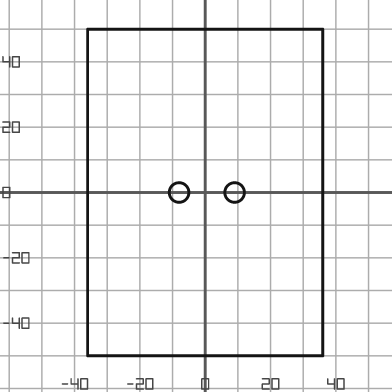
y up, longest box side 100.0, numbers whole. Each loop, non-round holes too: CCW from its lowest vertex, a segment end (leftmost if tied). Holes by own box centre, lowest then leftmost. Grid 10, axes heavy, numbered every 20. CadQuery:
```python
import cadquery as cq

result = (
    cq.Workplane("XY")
    .moveTo(-36.0, -50.0)
    .lineTo(36.0, -50.0)
    .lineTo(36.0, 50.0)
    .lineTo(-36.0, 50.0)
    .close()
    .moveTo(-8.0, 0.0)
    .circle(3.0)
    .moveTo(9.0, 0.0)
    .circle(3.0)
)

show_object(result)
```